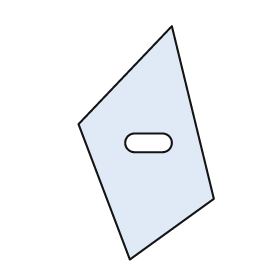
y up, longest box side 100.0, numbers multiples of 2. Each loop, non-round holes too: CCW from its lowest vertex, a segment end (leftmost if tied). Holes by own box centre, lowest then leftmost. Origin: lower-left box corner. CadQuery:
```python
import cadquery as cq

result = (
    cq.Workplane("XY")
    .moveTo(22.0, 0.0)
    .lineTo(58.0, 26.0)
    .lineTo(40.0, 100.0)
    .lineTo(0.0, 58.0)
    .close()
    .moveTo(24.0, 46.0)
    .lineTo(36.0, 46.0)
    .threePointArc((40.0, 50.0), (36.0, 54.0))
    .lineTo(24.0, 54.0)
    .threePointArc((20.0, 50.0), (24.0, 46.0))
    .close()
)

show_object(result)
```